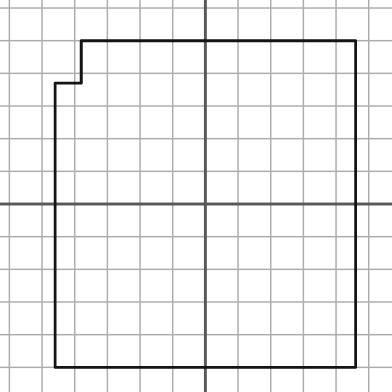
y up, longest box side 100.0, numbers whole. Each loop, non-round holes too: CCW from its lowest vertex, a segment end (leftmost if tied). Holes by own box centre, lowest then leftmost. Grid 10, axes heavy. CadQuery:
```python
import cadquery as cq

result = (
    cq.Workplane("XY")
    .moveTo(-46.0, -50.0)
    .lineTo(46.0, -50.0)
    .lineTo(46.0, 50.0)
    .lineTo(-38.0, 50.0)
    .lineTo(-38.0, 37.0)
    .lineTo(-46.0, 37.0)
    .close()
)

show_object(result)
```